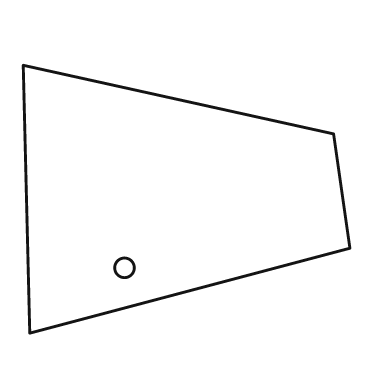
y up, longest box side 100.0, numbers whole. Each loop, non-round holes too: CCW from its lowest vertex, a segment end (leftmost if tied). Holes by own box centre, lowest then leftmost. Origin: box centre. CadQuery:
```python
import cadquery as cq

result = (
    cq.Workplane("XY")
    .moveTo(-48.0, -41.0)
    .lineTo(50.0, -15.0)
    .lineTo(45.0, 20.0)
    .lineTo(-50.0, 41.0)
    .close()
    .moveTo(-19.0, -21.0)
    .circle(3.0)
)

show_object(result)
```